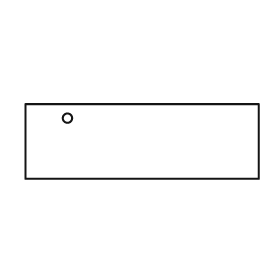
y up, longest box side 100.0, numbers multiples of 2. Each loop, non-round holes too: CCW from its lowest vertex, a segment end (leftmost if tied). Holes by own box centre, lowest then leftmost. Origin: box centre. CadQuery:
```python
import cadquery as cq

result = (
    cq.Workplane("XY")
    .moveTo(-50.0, -16.0)
    .lineTo(50.0, -16.0)
    .lineTo(50.0, 16.0)
    .lineTo(-50.0, 16.0)
    .close()
    .moveTo(-32.0, 10.0)
    .circle(2.0)
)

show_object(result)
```